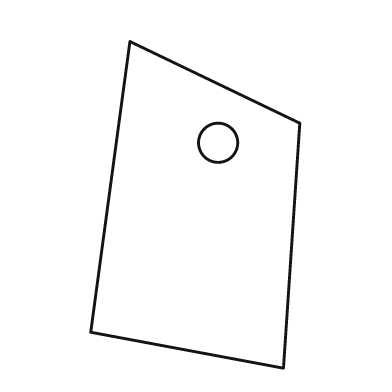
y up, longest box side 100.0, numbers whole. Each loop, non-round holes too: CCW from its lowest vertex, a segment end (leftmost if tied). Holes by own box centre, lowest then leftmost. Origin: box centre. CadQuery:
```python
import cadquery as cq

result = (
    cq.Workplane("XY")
    .moveTo(27.0, -50.0)
    .lineTo(32.0, 25.0)
    .lineTo(-20.0, 50.0)
    .lineTo(-32.0, -39.0)
    .close()
    .moveTo(7.0, 19.0)
    .circle(6.0)
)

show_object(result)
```